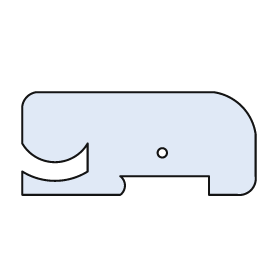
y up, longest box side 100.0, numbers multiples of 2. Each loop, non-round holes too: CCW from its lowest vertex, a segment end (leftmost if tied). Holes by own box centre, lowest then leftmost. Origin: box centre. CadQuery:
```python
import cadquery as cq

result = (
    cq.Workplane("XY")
    .moveTo(-50.0, -22.0)
    .lineTo(-8.0, -22.0)
    .threePointArc((-6.0, -18.0), (-8.0, -14.0))
    .lineTo(30.0, -14.0)
    .lineTo(30.0, -22.0)
    .lineTo(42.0, -22.0)
    .threePointArc((48.0, -20.0), (50.0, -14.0))
    .lineTo(50.0, 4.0)
    .threePointArc((44.0, 16.0), (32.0, 22.0))
    .lineTo(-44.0, 22.0)
    .threePointArc((-48.0, 20.0), (-50.0, 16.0))
    .lineTo(-50.0, 0.0)
    .threePointArc((-36.0, -8.0), (-22.0, 0.0))
    .lineTo(-22.0, -12.0)
    .threePointArc((-36.0, -16.0), (-50.0, -12.0))
    .close()
    .moveTo(10.0, -4.0)
    .circle(2.0)
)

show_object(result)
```